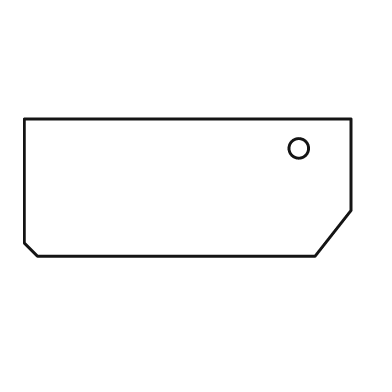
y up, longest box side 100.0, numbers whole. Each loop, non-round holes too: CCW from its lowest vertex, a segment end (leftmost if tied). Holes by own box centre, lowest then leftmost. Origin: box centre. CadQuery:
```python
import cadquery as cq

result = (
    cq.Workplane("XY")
    .moveTo(-46.0, -21.0)
    .lineTo(39.0, -21.0)
    .lineTo(50.0, -7.0)
    .lineTo(50.0, 21.0)
    .lineTo(-50.0, 21.0)
    .lineTo(-50.0, -17.0)
    .close()
    .moveTo(34.0, 12.0)
    .circle(3.0)
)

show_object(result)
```